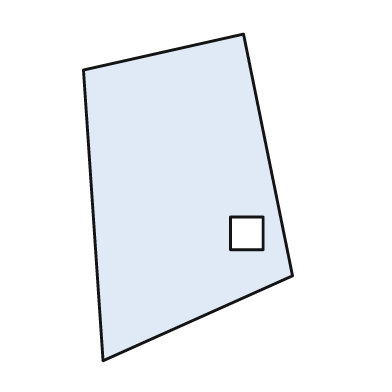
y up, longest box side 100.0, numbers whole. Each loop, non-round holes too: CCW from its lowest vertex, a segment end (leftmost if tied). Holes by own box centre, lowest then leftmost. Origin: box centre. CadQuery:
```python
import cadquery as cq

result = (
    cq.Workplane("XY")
    .moveTo(-26.0, -50.0)
    .lineTo(32.0, -24.0)
    .lineTo(17.0, 50.0)
    .lineTo(-32.0, 39.0)
    .close()
    .moveTo(13.0, -16.0)
    .lineTo(23.0, -16.0)
    .lineTo(23.0, -6.0)
    .lineTo(13.0, -6.0)
    .close()
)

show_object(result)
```